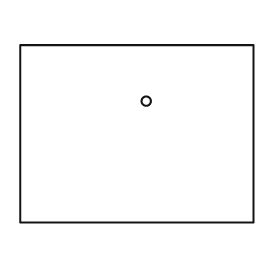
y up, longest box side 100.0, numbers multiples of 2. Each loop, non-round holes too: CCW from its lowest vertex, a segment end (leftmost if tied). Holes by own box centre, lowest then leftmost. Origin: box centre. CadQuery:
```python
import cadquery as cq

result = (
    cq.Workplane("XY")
    .moveTo(-50.0, -38.0)
    .lineTo(50.0, -38.0)
    .lineTo(50.0, 38.0)
    .lineTo(-50.0, 38.0)
    .close()
    .moveTo(4.0, 14.0)
    .circle(2.0)
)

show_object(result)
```